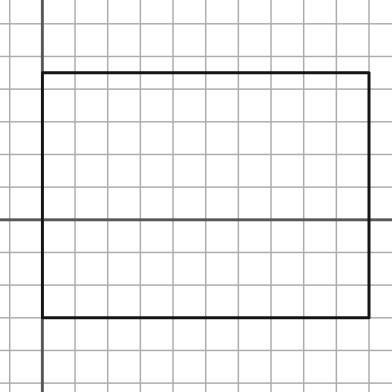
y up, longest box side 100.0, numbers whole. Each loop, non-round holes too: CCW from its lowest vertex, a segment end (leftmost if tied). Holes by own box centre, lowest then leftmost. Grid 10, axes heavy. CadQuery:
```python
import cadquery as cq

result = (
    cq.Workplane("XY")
    .moveTo(0.0, -30.0)
    .lineTo(100.0, -30.0)
    .lineTo(100.0, 45.0)
    .lineTo(0.0, 45.0)
    .close()
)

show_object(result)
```